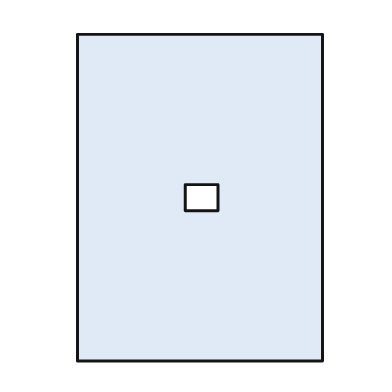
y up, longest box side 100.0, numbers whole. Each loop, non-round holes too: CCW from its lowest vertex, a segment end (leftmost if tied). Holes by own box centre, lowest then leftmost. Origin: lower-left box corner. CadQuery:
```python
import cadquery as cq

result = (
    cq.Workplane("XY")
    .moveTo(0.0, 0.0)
    .lineTo(75.0, 0.0)
    .lineTo(75.0, 100.0)
    .lineTo(0.0, 100.0)
    .close()
    .moveTo(33.0, 46.0)
    .lineTo(43.0, 46.0)
    .lineTo(43.0, 54.0)
    .lineTo(33.0, 54.0)
    .close()
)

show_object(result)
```